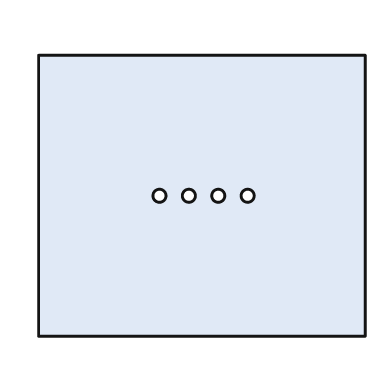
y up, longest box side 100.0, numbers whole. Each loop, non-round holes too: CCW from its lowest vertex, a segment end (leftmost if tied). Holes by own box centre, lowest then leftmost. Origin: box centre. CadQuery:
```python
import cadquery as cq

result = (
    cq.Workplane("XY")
    .moveTo(-50.0, -43.0)
    .lineTo(50.0, -43.0)
    .lineTo(50.0, 43.0)
    .lineTo(-50.0, 43.0)
    .close()
    .moveTo(-13.0, 0.0)
    .circle(2.0)
    .moveTo(-4.0, 0.0)
    .circle(2.0)
    .moveTo(5.0, 0.0)
    .circle(2.0)
    .moveTo(14.0, 0.0)
    .circle(2.0)
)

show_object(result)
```